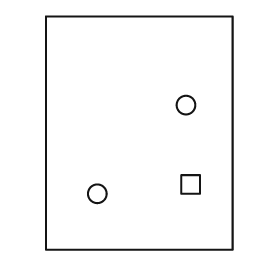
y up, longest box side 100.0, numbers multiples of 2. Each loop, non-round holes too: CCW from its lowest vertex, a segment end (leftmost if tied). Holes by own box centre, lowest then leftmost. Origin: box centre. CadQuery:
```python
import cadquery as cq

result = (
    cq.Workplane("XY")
    .moveTo(-40.0, -50.0)
    .lineTo(40.0, -50.0)
    .lineTo(40.0, 50.0)
    .lineTo(-40.0, 50.0)
    .close()
    .moveTo(-18.0, -26.0)
    .circle(4.0)
    .moveTo(18.0, -26.0)
    .lineTo(26.0, -26.0)
    .lineTo(26.0, -18.0)
    .lineTo(18.0, -18.0)
    .close()
    .moveTo(20.0, 12.0)
    .circle(4.0)
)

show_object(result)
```